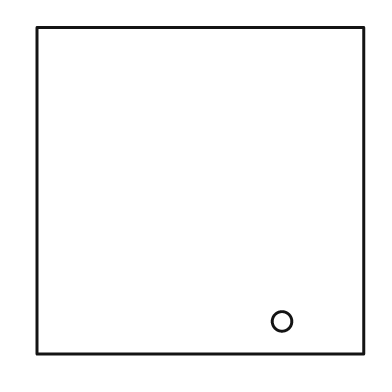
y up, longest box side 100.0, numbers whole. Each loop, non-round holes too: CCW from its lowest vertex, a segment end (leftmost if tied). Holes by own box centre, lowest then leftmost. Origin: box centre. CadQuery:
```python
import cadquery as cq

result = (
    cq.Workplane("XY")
    .moveTo(-50.0, -50.0)
    .lineTo(50.0, -50.0)
    .lineTo(50.0, 50.0)
    .lineTo(-50.0, 50.0)
    .close()
    .moveTo(25.0, -40.0)
    .circle(3.0)
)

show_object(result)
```